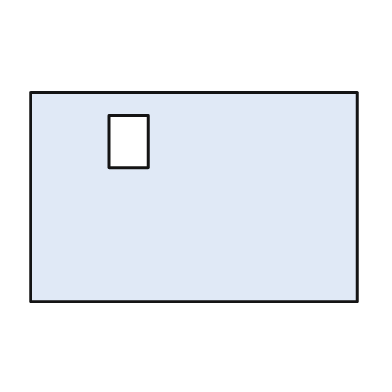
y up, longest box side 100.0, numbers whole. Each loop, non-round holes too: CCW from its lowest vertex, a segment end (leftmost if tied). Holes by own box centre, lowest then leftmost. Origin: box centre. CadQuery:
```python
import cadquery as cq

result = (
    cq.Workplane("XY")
    .moveTo(-50.0, -32.0)
    .lineTo(50.0, -32.0)
    .lineTo(50.0, 32.0)
    .lineTo(-50.0, 32.0)
    .close()
    .moveTo(-26.0, 9.0)
    .lineTo(-14.0, 9.0)
    .lineTo(-14.0, 25.0)
    .lineTo(-26.0, 25.0)
    .close()
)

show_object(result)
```